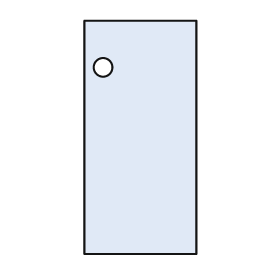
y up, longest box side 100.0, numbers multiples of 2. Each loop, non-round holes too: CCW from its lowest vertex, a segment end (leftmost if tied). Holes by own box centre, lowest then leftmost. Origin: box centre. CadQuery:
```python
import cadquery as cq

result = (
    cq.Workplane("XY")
    .moveTo(-24.0, -50.0)
    .lineTo(24.0, -50.0)
    .lineTo(24.0, 50.0)
    .lineTo(-24.0, 50.0)
    .close()
    .moveTo(-16.0, 30.0)
    .circle(4.0)
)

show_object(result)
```